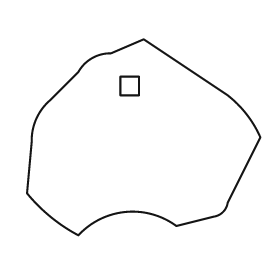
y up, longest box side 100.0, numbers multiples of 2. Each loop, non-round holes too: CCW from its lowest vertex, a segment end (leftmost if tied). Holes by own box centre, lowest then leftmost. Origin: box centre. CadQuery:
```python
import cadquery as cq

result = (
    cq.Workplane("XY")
    .moveTo(-28.0, -42.0)
    .threePointArc((-8.0, -32.0), (14.0, -38.0))
    .lineTo(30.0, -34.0)
    .threePointArc((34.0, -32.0), (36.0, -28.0))
    .lineTo(50.0, 0.0)
    .threePointArc((44.0, 10.0), (36.0, 18.0))
    .lineTo(0.0, 42.0)
    .lineTo(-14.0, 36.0)
    .threePointArc((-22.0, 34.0), (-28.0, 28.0))
    .lineTo(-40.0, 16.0)
    .threePointArc((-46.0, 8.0), (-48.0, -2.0))
    .lineTo(-50.0, -24.0)
    .threePointArc((-40.0, -34.0), (-28.0, -42.0))
    .close()
    .moveTo(-10.0, 18.0)
    .lineTo(-2.0, 18.0)
    .lineTo(-2.0, 26.0)
    .lineTo(-10.0, 26.0)
    .close()
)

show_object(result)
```